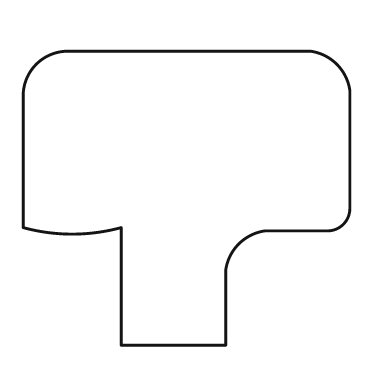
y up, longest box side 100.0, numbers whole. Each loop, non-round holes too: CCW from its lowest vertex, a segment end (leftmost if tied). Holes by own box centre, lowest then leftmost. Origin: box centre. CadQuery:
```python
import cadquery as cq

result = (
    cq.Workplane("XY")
    .moveTo(-20.0, -45.0)
    .lineTo(12.0, -45.0)
    .lineTo(12.0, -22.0)
    .threePointArc((16.0, -14.0), (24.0, -10.0))
    .lineTo(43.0, -10.0)
    .threePointArc((48.0, -8.0), (50.0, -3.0))
    .lineTo(50.0, 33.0)
    .threePointArc((46.0, 41.0), (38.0, 45.0))
    .lineTo(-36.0, 45.0)
    .threePointArc((-46.0, 41.0), (-50.0, 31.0))
    .lineTo(-50.0, -9.0)
    .threePointArc((-35.0, -11.0), (-20.0, -9.0))
    .close()
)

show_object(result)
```